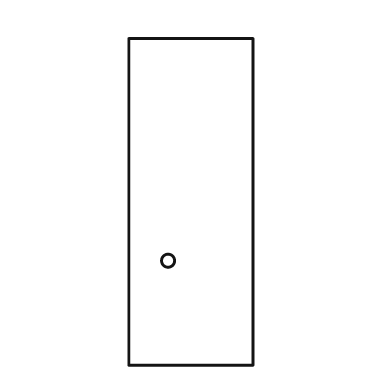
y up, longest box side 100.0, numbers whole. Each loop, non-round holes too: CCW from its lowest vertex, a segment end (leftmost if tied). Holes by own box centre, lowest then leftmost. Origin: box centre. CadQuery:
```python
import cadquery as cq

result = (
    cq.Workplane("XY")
    .moveTo(-19.0, -50.0)
    .lineTo(19.0, -50.0)
    .lineTo(19.0, 50.0)
    .lineTo(-19.0, 50.0)
    .close()
    .moveTo(-7.0, -18.0)
    .circle(2.0)
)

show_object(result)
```